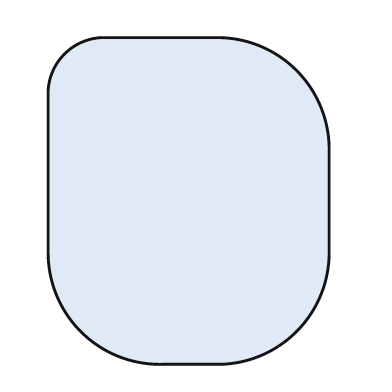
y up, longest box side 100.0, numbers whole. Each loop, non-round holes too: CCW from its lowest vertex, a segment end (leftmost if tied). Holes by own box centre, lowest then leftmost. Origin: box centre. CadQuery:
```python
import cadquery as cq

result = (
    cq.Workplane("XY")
    .moveTo(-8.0, -50.0)
    .lineTo(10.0, -50.0)
    .threePointArc((33.0, -40.0), (43.0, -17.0))
    .lineTo(43.0, 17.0)
    .threePointArc((33.0, 40.0), (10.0, 50.0))
    .lineTo(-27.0, 50.0)
    .threePointArc((-38.0, 45.0), (-43.0, 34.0))
    .lineTo(-43.0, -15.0)
    .threePointArc((-33.0, -40.0), (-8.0, -50.0))
    .close()
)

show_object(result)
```